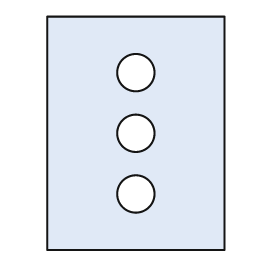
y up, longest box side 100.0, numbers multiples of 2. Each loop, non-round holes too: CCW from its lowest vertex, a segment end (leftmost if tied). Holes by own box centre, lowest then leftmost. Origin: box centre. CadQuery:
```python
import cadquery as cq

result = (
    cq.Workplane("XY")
    .moveTo(-38.0, -50.0)
    .lineTo(38.0, -50.0)
    .lineTo(38.0, 50.0)
    .lineTo(-38.0, 50.0)
    .close()
    .moveTo(0.0, -26.0)
    .circle(8.0)
    .moveTo(0.0, 0.0)
    .circle(8.0)
    .moveTo(0.0, 26.0)
    .circle(8.0)
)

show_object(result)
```